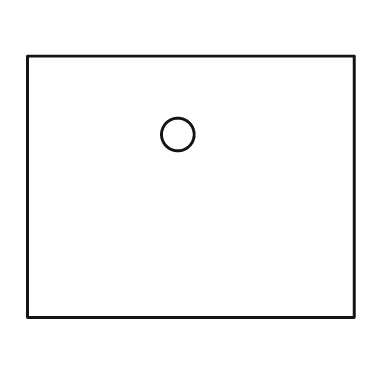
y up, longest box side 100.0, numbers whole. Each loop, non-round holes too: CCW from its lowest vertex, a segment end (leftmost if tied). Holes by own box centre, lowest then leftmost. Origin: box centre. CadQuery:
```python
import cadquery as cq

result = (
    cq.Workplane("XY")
    .moveTo(-50.0, -40.0)
    .lineTo(50.0, -40.0)
    .lineTo(50.0, 40.0)
    .lineTo(-50.0, 40.0)
    .close()
    .moveTo(-4.0, 16.0)
    .circle(5.0)
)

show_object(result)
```